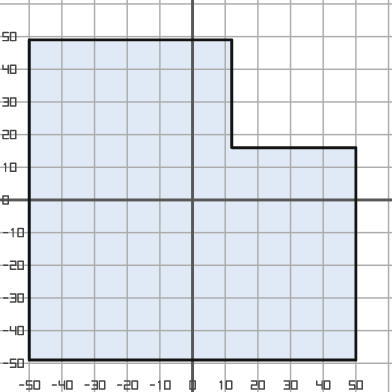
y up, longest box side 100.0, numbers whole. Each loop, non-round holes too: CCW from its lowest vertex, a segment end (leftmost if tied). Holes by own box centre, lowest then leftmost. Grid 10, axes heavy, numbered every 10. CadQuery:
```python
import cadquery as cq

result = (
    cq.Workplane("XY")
    .moveTo(-50.0, -49.0)
    .lineTo(50.0, -49.0)
    .lineTo(50.0, 16.0)
    .lineTo(12.0, 16.0)
    .lineTo(12.0, 49.0)
    .lineTo(-50.0, 49.0)
    .close()
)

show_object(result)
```